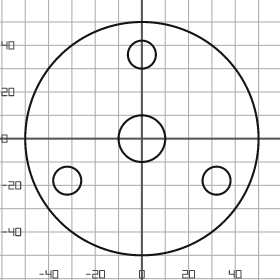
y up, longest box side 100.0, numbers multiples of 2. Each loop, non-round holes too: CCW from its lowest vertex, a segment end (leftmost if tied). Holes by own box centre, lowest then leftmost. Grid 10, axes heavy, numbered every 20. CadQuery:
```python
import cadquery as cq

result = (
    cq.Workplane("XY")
    .moveTo(0.0, 0.0)
    .circle(50.0)
    .moveTo(-32.0, -18.0)
    .circle(6.0)
    .moveTo(32.0, -18.0)
    .circle(6.0)
    .moveTo(0.0, 0.0)
    .circle(10.0)
    .moveTo(0.0, 36.0)
    .circle(6.0)
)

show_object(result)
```